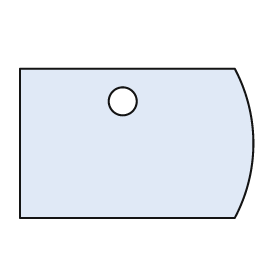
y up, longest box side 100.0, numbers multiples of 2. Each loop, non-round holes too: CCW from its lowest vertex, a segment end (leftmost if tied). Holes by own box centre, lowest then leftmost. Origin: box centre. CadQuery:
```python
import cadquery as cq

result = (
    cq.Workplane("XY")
    .moveTo(-50.0, -32.0)
    .lineTo(42.0, -32.0)
    .threePointArc((50.0, 0.0), (42.0, 32.0))
    .lineTo(-50.0, 32.0)
    .close()
    .moveTo(-6.0, 18.0)
    .circle(6.0)
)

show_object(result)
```